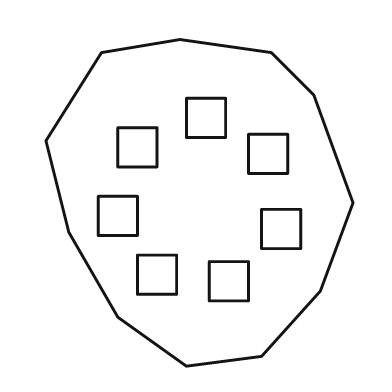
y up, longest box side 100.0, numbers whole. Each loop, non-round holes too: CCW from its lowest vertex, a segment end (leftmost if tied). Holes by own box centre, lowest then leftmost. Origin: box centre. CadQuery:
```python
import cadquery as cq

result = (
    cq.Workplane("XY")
    .moveTo(-4.0, -50.0)
    .lineTo(19.0, -47.0)
    .lineTo(37.0, -27.0)
    .lineTo(47.0, 0.0)
    .lineTo(35.0, 33.0)
    .lineTo(22.0, 46.0)
    .lineTo(-6.0, 50.0)
    .lineTo(-30.0, 46.0)
    .lineTo(-47.0, 19.0)
    .lineTo(-40.0, -9.0)
    .lineTo(-25.0, -35.0)
    .close()
    .moveTo(3.0, -30.0)
    .lineTo(15.0, -30.0)
    .lineTo(15.0, -18.0)
    .lineTo(3.0, -18.0)
    .close()
    .moveTo(-19.0, -28.0)
    .lineTo(-7.0, -28.0)
    .lineTo(-7.0, -16.0)
    .lineTo(-19.0, -16.0)
    .close()
    .moveTo(19.0, -14.0)
    .lineTo(31.0, -14.0)
    .lineTo(31.0, -2.0)
    .lineTo(19.0, -2.0)
    .close()
    .moveTo(-31.0, -10.0)
    .lineTo(-19.0, -10.0)
    .lineTo(-19.0, 2.0)
    .lineTo(-31.0, 2.0)
    .close()
    .moveTo(15.0, 9.0)
    .lineTo(27.0, 9.0)
    .lineTo(27.0, 21.0)
    .lineTo(15.0, 21.0)
    .close()
    .moveTo(-25.0, 11.0)
    .lineTo(-13.0, 11.0)
    .lineTo(-13.0, 23.0)
    .lineTo(-25.0, 23.0)
    .close()
    .moveTo(-4.0, 20.0)
    .lineTo(8.0, 20.0)
    .lineTo(8.0, 32.0)
    .lineTo(-4.0, 32.0)
    .close()
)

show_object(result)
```